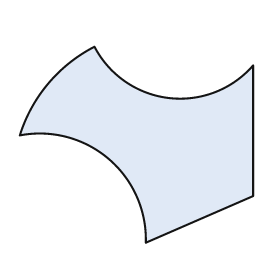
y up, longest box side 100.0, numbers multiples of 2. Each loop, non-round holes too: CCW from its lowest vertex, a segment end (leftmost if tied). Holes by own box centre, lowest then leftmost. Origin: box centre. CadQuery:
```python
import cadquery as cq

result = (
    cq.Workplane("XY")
    .moveTo(4.0, -42.0)
    .lineTo(50.0, -22.0)
    .lineTo(50.0, 34.0)
    .threePointArc((14.0, 20.0), (-18.0, 42.0))
    .threePointArc((-38.0, 26.0), (-50.0, 4.0))
    .threePointArc((-12.0, -6.0), (4.0, -42.0))
    .close()
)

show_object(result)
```